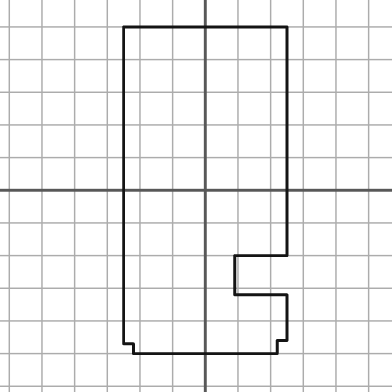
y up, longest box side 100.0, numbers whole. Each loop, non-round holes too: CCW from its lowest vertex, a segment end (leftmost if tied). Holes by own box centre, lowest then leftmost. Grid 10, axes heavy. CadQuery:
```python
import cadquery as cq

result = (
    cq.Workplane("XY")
    .moveTo(-22.0, -50.0)
    .lineTo(22.0, -50.0)
    .lineTo(22.0, -46.0)
    .lineTo(25.0, -46.0)
    .lineTo(25.0, -32.0)
    .lineTo(9.0, -32.0)
    .lineTo(9.0, -20.0)
    .lineTo(25.0, -20.0)
    .lineTo(25.0, 50.0)
    .lineTo(-25.0, 50.0)
    .lineTo(-25.0, -47.0)
    .lineTo(-22.0, -47.0)
    .close()
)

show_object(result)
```